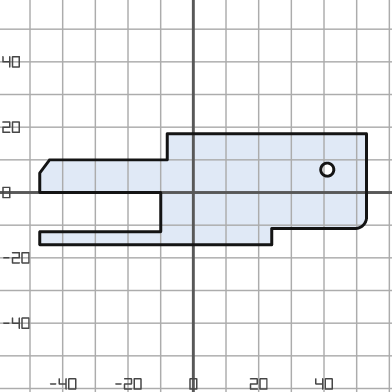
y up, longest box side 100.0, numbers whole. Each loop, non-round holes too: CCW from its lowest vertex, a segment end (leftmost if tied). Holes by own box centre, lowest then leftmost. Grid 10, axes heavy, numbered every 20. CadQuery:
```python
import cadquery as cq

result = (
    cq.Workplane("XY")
    .moveTo(-47.0, -16.0)
    .lineTo(24.0, -16.0)
    .lineTo(24.0, -11.0)
    .lineTo(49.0, -11.0)
    .threePointArc((52.0, -10.0), (53.0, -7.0))
    .lineTo(53.0, 18.0)
    .lineTo(-8.0, 18.0)
    .lineTo(-8.0, 10.0)
    .lineTo(-44.0, 10.0)
    .lineTo(-47.0, 6.0)
    .lineTo(-47.0, 0.0)
    .lineTo(-10.0, 0.0)
    .lineTo(-10.0, -12.0)
    .lineTo(-47.0, -12.0)
    .close()
    .moveTo(41.0, 7.0)
    .circle(2.0)
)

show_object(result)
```